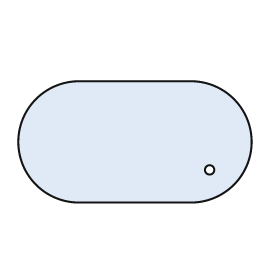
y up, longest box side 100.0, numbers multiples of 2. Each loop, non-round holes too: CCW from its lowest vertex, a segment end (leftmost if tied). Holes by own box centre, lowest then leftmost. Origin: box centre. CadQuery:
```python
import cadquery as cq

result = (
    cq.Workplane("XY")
    .moveTo(-24.0, -26.0)
    .lineTo(24.0, -26.0)
    .threePointArc((50.0, 0.0), (24.0, 26.0))
    .lineTo(-24.0, 26.0)
    .threePointArc((-50.0, 0.0), (-24.0, -26.0))
    .close()
    .moveTo(32.0, -12.0)
    .circle(2.0)
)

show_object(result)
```